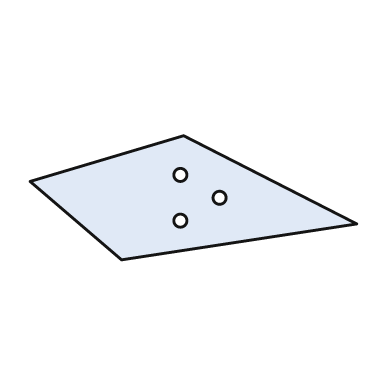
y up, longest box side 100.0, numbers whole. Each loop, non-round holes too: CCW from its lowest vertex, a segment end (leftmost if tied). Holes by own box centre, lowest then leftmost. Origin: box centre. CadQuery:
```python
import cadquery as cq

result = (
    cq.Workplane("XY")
    .moveTo(-22.0, -19.0)
    .lineTo(50.0, -8.0)
    .lineTo(-3.0, 19.0)
    .lineTo(-50.0, 5.0)
    .close()
    .moveTo(-4.0, -7.0)
    .circle(2.0)
    .moveTo(8.0, 0.0)
    .circle(2.0)
    .moveTo(-4.0, 7.0)
    .circle(2.0)
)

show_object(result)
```